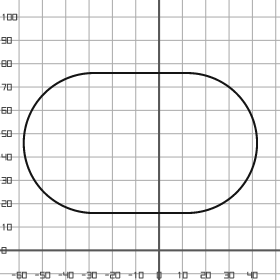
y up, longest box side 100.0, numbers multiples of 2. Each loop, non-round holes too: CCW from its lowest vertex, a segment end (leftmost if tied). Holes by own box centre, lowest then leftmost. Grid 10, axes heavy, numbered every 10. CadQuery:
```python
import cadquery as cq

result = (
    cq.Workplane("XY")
    .moveTo(-28.0, 16.0)
    .lineTo(12.0, 16.0)
    .threePointArc((42.0, 46.0), (12.0, 76.0))
    .lineTo(-28.0, 76.0)
    .threePointArc((-58.0, 46.0), (-28.0, 16.0))
    .close()
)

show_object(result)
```